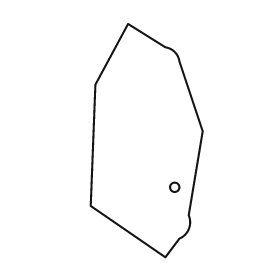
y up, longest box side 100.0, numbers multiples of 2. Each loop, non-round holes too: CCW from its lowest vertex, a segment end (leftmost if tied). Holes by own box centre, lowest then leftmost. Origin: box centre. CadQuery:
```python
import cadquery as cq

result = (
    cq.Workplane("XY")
    .moveTo(8.0, -50.0)
    .lineTo(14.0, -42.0)
    .threePointArc((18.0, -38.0), (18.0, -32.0))
    .lineTo(24.0, 4.0)
    .lineTo(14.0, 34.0)
    .threePointArc((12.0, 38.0), (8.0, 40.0))
    .lineTo(-8.0, 50.0)
    .lineTo(-22.0, 24.0)
    .lineTo(-24.0, -28.0)
    .close()
    .moveTo(12.0, -20.0)
    .circle(2.0)
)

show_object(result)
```